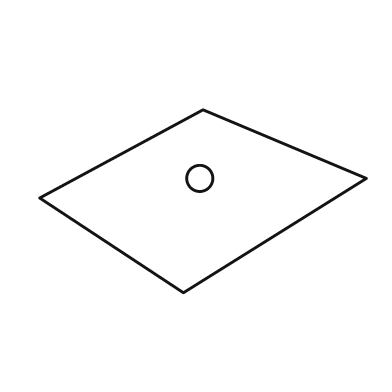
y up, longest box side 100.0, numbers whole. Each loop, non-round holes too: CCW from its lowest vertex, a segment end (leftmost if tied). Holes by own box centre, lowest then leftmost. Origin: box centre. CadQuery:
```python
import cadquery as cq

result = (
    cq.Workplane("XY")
    .moveTo(-6.0, -28.0)
    .lineTo(50.0, 7.0)
    .lineTo(0.0, 28.0)
    .lineTo(-50.0, 1.0)
    .close()
    .moveTo(-1.0, 7.0)
    .circle(4.0)
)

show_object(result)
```